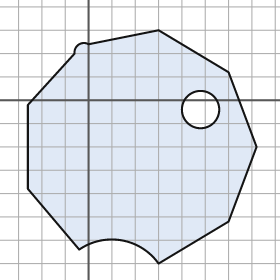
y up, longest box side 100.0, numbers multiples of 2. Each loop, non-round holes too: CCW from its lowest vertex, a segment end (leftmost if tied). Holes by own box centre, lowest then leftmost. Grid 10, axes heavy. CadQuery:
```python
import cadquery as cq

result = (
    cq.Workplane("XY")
    .moveTo(30.0, -70.0)
    .lineTo(60.0, -52.0)
    .lineTo(72.0, -20.0)
    .lineTo(60.0, 12.0)
    .lineTo(30.0, 30.0)
    .lineTo(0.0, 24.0)
    .threePointArc((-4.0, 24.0), (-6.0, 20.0))
    .lineTo(-26.0, -2.0)
    .lineTo(-26.0, -38.0)
    .lineTo(-4.0, -64.0)
    .threePointArc((14.0, -60.0), (30.0, -70.0))
    .close()
    .moveTo(48.0, -4.0)
    .circle(8.0)
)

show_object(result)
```